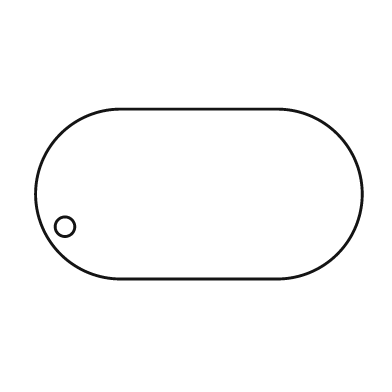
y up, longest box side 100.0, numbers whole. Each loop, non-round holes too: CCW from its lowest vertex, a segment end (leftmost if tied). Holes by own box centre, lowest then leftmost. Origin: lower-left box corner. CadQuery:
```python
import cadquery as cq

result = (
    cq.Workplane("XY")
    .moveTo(26.0, 0.0)
    .lineTo(74.0, 0.0)
    .threePointArc((100.0, 26.0), (74.0, 52.0))
    .lineTo(26.0, 52.0)
    .threePointArc((0.0, 26.0), (26.0, 0.0))
    .close()
    .moveTo(9.0, 16.0)
    .circle(3.0)
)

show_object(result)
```